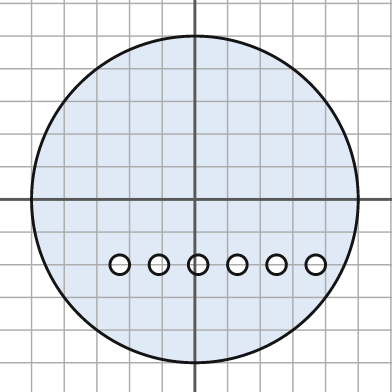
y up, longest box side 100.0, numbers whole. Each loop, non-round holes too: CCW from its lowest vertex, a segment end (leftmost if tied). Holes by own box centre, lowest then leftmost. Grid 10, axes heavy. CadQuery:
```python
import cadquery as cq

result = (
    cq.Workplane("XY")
    .moveTo(0.0, 0.0)
    .circle(50.0)
    .moveTo(-23.0, -20.0)
    .circle(3.0)
    .moveTo(-11.0, -20.0)
    .circle(3.0)
    .moveTo(1.0, -20.0)
    .circle(3.0)
    .moveTo(13.0, -20.0)
    .circle(3.0)
    .moveTo(25.0, -20.0)
    .circle(3.0)
    .moveTo(37.0, -20.0)
    .circle(3.0)
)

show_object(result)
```